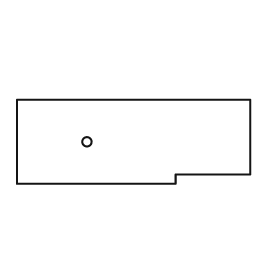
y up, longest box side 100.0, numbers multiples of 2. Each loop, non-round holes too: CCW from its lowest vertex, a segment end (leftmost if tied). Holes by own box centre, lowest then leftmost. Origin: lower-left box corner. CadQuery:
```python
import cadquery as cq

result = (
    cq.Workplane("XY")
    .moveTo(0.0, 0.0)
    .lineTo(68.0, 0.0)
    .lineTo(68.0, 4.0)
    .lineTo(100.0, 4.0)
    .lineTo(100.0, 36.0)
    .lineTo(0.0, 36.0)
    .close()
    .moveTo(30.0, 18.0)
    .circle(2.0)
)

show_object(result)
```